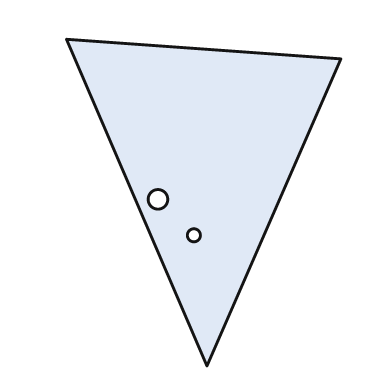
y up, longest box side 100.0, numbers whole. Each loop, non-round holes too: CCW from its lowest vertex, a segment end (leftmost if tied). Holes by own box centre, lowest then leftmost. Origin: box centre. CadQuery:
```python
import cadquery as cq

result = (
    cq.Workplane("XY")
    .moveTo(1.0, -50.0)
    .lineTo(42.0, 44.0)
    .lineTo(-42.0, 50.0)
    .close()
    .moveTo(-3.0, -10.0)
    .circle(2.0)
    .moveTo(-14.0, 1.0)
    .circle(3.0)
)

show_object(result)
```